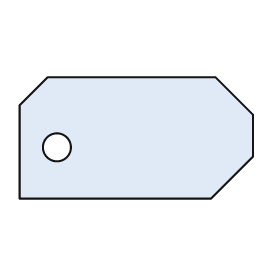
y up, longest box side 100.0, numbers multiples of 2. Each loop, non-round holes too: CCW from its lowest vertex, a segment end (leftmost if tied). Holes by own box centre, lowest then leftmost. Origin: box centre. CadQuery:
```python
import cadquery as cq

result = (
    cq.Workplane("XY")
    .moveTo(-50.0, -26.0)
    .lineTo(32.0, -26.0)
    .lineTo(50.0, -8.0)
    .lineTo(50.0, 10.0)
    .lineTo(34.0, 26.0)
    .lineTo(-38.0, 26.0)
    .lineTo(-50.0, 14.0)
    .close()
    .moveTo(-34.0, -4.0)
    .circle(6.0)
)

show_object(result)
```